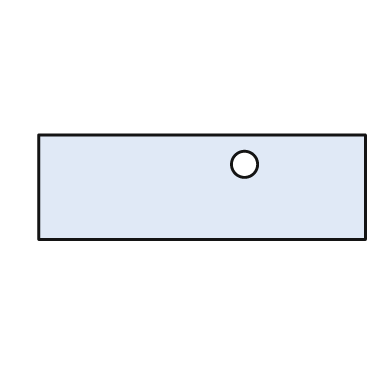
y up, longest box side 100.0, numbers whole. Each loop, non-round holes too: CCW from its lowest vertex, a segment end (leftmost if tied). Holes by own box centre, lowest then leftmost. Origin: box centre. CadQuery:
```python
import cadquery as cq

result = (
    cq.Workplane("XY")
    .moveTo(-50.0, -16.0)
    .lineTo(50.0, -16.0)
    .lineTo(50.0, 16.0)
    .lineTo(-50.0, 16.0)
    .close()
    .moveTo(13.0, 7.0)
    .circle(4.0)
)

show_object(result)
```